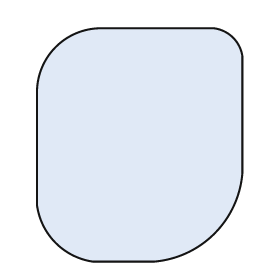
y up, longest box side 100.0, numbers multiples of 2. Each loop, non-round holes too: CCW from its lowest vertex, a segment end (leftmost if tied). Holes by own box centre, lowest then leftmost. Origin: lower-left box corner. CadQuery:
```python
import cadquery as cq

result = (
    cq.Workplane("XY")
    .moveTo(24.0, 0.0)
    .lineTo(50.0, 0.0)
    .threePointArc((76.0, 12.0), (88.0, 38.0))
    .lineTo(88.0, 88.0)
    .threePointArc((84.0, 96.0), (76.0, 100.0))
    .lineTo(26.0, 100.0)
    .threePointArc((8.0, 92.0), (0.0, 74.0))
    .lineTo(0.0, 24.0)
    .threePointArc((8.0, 8.0), (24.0, 0.0))
    .close()
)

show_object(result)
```